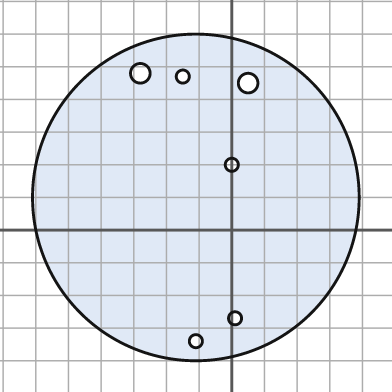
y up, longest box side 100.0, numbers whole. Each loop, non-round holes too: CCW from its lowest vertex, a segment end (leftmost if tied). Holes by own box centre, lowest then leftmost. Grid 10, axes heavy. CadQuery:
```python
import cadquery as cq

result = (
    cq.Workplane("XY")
    .moveTo(-11.0, 10.0)
    .circle(50.0)
    .moveTo(-11.0, -34.0)
    .circle(2.0)
    .moveTo(1.0, -27.0)
    .circle(2.0)
    .moveTo(0.0, 20.0)
    .circle(2.0)
    .moveTo(5.0, 45.0)
    .circle(3.0)
    .moveTo(-15.0, 47.0)
    .circle(2.0)
    .moveTo(-28.0, 48.0)
    .circle(3.0)
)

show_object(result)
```